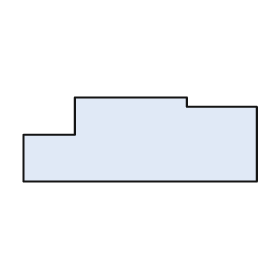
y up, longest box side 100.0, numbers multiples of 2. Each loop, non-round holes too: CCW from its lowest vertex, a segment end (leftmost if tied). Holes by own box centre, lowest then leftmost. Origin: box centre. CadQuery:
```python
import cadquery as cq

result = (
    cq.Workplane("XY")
    .moveTo(-50.0, -18.0)
    .lineTo(50.0, -18.0)
    .lineTo(50.0, 14.0)
    .lineTo(20.0, 14.0)
    .lineTo(20.0, 18.0)
    .lineTo(-28.0, 18.0)
    .lineTo(-28.0, 2.0)
    .lineTo(-50.0, 2.0)
    .close()
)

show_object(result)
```